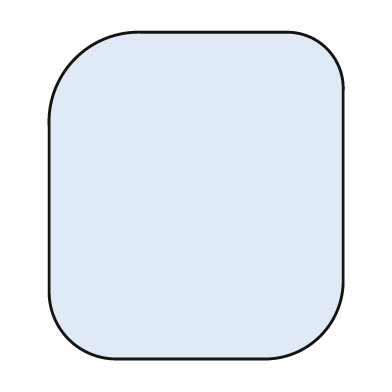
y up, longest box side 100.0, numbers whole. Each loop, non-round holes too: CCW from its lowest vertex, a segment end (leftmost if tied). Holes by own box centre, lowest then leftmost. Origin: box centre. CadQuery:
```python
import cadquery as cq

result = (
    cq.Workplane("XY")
    .moveTo(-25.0, -50.0)
    .lineTo(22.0, -50.0)
    .threePointArc((38.0, -43.0), (45.0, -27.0))
    .lineTo(45.0, 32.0)
    .threePointArc((40.0, 45.0), (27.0, 50.0))
    .lineTo(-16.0, 50.0)
    .threePointArc((-37.0, 42.0), (-45.0, 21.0))
    .lineTo(-45.0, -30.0)
    .threePointArc((-39.0, -44.0), (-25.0, -50.0))
    .close()
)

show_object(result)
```